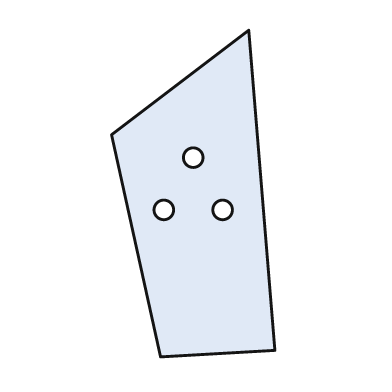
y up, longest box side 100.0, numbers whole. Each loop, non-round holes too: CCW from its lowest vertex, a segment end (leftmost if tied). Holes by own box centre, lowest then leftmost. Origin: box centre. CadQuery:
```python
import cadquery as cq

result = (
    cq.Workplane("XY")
    .moveTo(-10.0, -50.0)
    .lineTo(25.0, -48.0)
    .lineTo(17.0, 50.0)
    .lineTo(-25.0, 18.0)
    .close()
    .moveTo(-9.0, -5.0)
    .circle(3.0)
    .moveTo(9.0, -5.0)
    .circle(3.0)
    .moveTo(0.0, 11.0)
    .circle(3.0)
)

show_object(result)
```